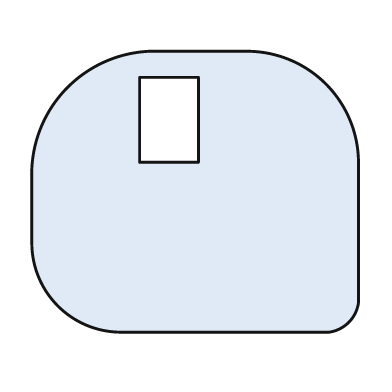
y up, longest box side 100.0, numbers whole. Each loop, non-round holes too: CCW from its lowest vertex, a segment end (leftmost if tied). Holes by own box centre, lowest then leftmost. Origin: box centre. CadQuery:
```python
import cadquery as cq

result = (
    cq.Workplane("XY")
    .moveTo(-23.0, -43.0)
    .lineTo(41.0, -43.0)
    .threePointArc((47.0, -40.0), (50.0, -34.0))
    .lineTo(50.0, 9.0)
    .threePointArc((40.0, 33.0), (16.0, 43.0))
    .lineTo(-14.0, 43.0)
    .threePointArc((-39.0, 32.0), (-50.0, 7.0))
    .lineTo(-50.0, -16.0)
    .threePointArc((-42.0, -35.0), (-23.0, -43.0))
    .close()
    .moveTo(-17.0, 9.0)
    .lineTo(1.0, 9.0)
    .lineTo(1.0, 35.0)
    .lineTo(-17.0, 35.0)
    .close()
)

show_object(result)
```